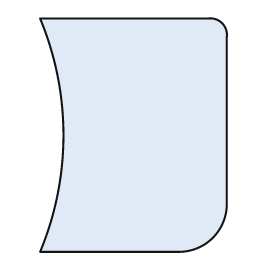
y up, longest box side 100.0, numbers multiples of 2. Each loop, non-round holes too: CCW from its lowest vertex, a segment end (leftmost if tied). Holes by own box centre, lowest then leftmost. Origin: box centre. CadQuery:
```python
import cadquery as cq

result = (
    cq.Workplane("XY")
    .moveTo(-40.0, -50.0)
    .lineTo(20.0, -50.0)
    .threePointArc((34.0, -44.0), (40.0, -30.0))
    .lineTo(40.0, 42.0)
    .threePointArc((38.0, 48.0), (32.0, 50.0))
    .lineTo(-40.0, 50.0)
    .threePointArc((-30.0, 0.0), (-40.0, -50.0))
    .close()
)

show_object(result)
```